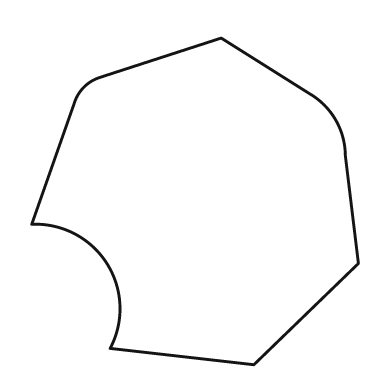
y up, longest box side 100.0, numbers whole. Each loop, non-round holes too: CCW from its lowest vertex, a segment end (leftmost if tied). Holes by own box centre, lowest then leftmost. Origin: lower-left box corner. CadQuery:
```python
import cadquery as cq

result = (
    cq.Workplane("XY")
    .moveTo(68.0, 0.0)
    .lineTo(100.0, 31.0)
    .lineTo(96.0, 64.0)
    .threePointArc((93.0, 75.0), (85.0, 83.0))
    .lineTo(58.0, 100.0)
    .lineTo(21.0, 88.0)
    .threePointArc((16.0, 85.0), (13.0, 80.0))
    .lineTo(0.0, 43.0)
    .threePointArc((23.0, 31.0), (24.0, 5.0))
    .close()
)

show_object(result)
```